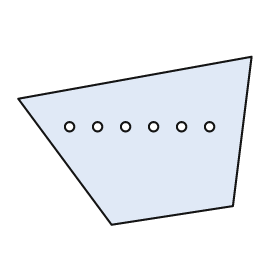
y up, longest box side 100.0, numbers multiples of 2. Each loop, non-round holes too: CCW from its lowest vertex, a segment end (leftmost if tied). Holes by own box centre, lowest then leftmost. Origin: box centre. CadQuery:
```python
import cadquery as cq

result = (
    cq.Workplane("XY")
    .moveTo(-10.0, -36.0)
    .lineTo(42.0, -28.0)
    .lineTo(50.0, 36.0)
    .lineTo(-50.0, 18.0)
    .close()
    .moveTo(-28.0, 6.0)
    .circle(2.0)
    .moveTo(-16.0, 6.0)
    .circle(2.0)
    .moveTo(-4.0, 6.0)
    .circle(2.0)
    .moveTo(8.0, 6.0)
    .circle(2.0)
    .moveTo(20.0, 6.0)
    .circle(2.0)
    .moveTo(32.0, 6.0)
    .circle(2.0)
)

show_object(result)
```